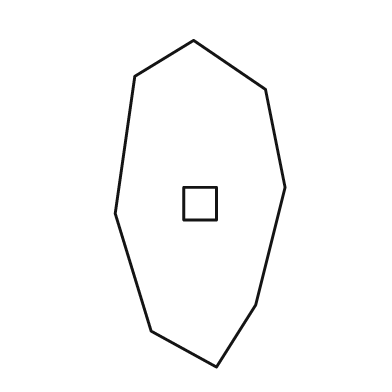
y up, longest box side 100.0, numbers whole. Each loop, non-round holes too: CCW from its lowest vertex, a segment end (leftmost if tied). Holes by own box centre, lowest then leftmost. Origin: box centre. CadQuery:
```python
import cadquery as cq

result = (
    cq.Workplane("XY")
    .moveTo(5.0, -50.0)
    .lineTo(17.0, -31.0)
    .lineTo(26.0, 5.0)
    .lineTo(20.0, 35.0)
    .lineTo(-2.0, 50.0)
    .lineTo(-20.0, 39.0)
    .lineTo(-26.0, -3.0)
    .lineTo(-15.0, -39.0)
    .close()
    .moveTo(-5.0, -5.0)
    .lineTo(5.0, -5.0)
    .lineTo(5.0, 5.0)
    .lineTo(-5.0, 5.0)
    .close()
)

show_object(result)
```